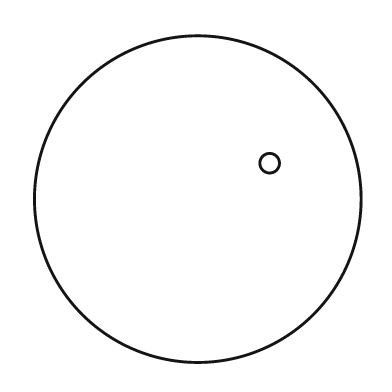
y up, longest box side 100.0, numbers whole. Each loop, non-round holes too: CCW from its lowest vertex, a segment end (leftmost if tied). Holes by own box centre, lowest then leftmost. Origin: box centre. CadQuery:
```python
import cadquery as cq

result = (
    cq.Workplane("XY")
    .moveTo(0.0, 0.0)
    .circle(50.0)
    .moveTo(22.0, 11.0)
    .circle(3.0)
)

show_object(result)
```